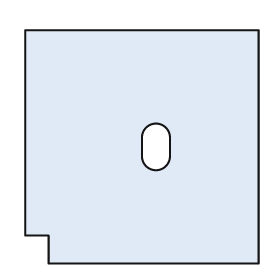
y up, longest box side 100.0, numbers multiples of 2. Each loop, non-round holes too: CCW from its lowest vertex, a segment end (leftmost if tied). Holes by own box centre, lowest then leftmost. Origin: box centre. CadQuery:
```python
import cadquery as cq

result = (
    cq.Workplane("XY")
    .moveTo(-40.0, -50.0)
    .lineTo(50.0, -50.0)
    .lineTo(50.0, 50.0)
    .lineTo(-50.0, 50.0)
    .lineTo(-50.0, -38.0)
    .lineTo(-40.0, -38.0)
    .close()
    .moveTo(0.0, -4.0)
    .threePointArc((6.0, -10.0), (12.0, -4.0))
    .lineTo(12.0, 4.0)
    .threePointArc((6.0, 10.0), (0.0, 4.0))
    .close()
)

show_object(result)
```